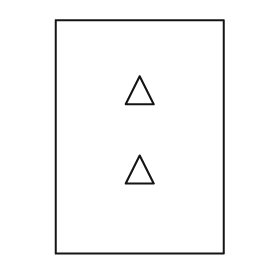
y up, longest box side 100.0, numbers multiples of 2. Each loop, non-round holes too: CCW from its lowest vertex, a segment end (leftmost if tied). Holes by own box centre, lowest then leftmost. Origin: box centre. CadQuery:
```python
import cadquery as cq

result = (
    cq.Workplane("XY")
    .moveTo(-36.0, -50.0)
    .lineTo(36.0, -50.0)
    .lineTo(36.0, 50.0)
    .lineTo(-36.0, 50.0)
    .close()
    .moveTo(-6.0, -20.0)
    .lineTo(6.0, -20.0)
    .lineTo(0.0, -8.0)
    .close()
    .moveTo(-6.0, 14.0)
    .lineTo(6.0, 14.0)
    .lineTo(0.0, 26.0)
    .close()
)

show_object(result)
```